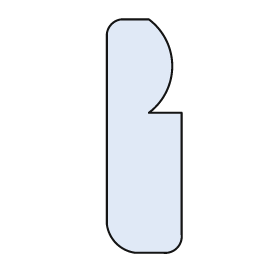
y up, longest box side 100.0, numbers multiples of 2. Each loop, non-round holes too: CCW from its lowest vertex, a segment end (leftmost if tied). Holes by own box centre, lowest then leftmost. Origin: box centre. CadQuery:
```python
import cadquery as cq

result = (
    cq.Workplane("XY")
    .moveTo(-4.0, -50.0)
    .lineTo(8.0, -50.0)
    .threePointArc((14.0, -48.0), (16.0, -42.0))
    .lineTo(16.0, 10.0)
    .lineTo(2.0, 10.0)
    .threePointArc((12.0, 30.0), (2.0, 50.0))
    .lineTo(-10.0, 50.0)
    .threePointArc((-14.0, 48.0), (-16.0, 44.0))
    .lineTo(-16.0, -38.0)
    .threePointArc((-12.0, -46.0), (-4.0, -50.0))
    .close()
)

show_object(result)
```